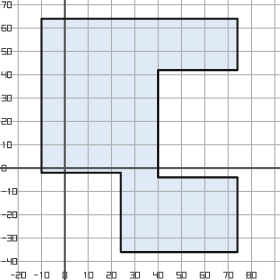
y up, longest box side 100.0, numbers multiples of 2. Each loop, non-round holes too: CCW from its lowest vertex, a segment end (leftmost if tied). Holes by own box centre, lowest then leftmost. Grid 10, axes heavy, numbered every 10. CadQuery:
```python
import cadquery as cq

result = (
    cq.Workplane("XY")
    .moveTo(24.0, -36.0)
    .lineTo(74.0, -36.0)
    .lineTo(74.0, -4.0)
    .lineTo(40.0, -4.0)
    .lineTo(40.0, 42.0)
    .lineTo(74.0, 42.0)
    .lineTo(74.0, 64.0)
    .lineTo(-10.0, 64.0)
    .lineTo(-10.0, -2.0)
    .lineTo(24.0, -2.0)
    .close()
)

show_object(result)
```